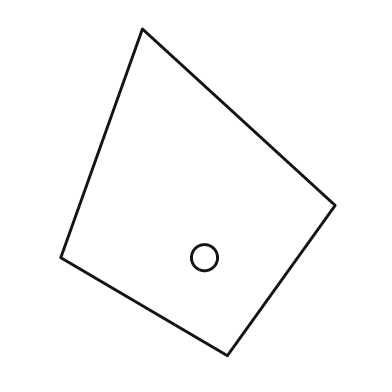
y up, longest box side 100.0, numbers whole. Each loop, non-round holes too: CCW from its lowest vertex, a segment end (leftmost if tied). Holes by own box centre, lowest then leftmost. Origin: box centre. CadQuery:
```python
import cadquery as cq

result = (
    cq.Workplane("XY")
    .moveTo(9.0, -50.0)
    .lineTo(42.0, -4.0)
    .lineTo(-17.0, 50.0)
    .lineTo(-42.0, -20.0)
    .close()
    .moveTo(2.0, -20.0)
    .circle(4.0)
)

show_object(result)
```